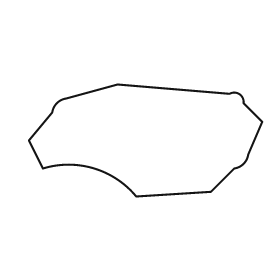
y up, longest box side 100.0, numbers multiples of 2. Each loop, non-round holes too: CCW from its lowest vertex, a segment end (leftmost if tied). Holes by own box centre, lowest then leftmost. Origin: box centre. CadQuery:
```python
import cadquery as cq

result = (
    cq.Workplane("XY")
    .moveTo(-4.0, -24.0)
    .lineTo(28.0, -22.0)
    .lineTo(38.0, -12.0)
    .threePointArc((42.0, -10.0), (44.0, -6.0))
    .lineTo(50.0, 8.0)
    .lineTo(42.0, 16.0)
    .threePointArc((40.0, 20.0), (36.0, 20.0))
    .lineTo(-12.0, 24.0)
    .lineTo(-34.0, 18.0)
    .threePointArc((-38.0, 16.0), (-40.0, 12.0))
    .lineTo(-50.0, 0.0)
    .lineTo(-44.0, -12.0)
    .threePointArc((-22.0, -12.0), (-4.0, -24.0))
    .close()
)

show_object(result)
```